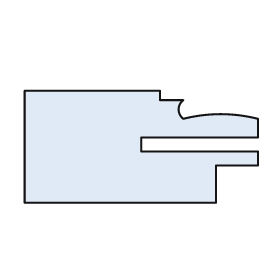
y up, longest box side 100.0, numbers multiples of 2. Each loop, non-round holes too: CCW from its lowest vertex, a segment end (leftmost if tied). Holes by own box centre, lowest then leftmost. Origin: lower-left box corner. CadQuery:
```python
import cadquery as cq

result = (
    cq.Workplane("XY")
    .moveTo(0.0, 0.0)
    .lineTo(82.0, 0.0)
    .lineTo(82.0, 16.0)
    .lineTo(100.0, 16.0)
    .lineTo(100.0, 22.0)
    .lineTo(50.0, 22.0)
    .lineTo(50.0, 28.0)
    .lineTo(100.0, 28.0)
    .lineTo(100.0, 36.0)
    .threePointArc((84.0, 38.0), (68.0, 36.0))
    .threePointArc((66.0, 40.0), (68.0, 44.0))
    .lineTo(58.0, 44.0)
    .lineTo(58.0, 48.0)
    .lineTo(0.0, 48.0)
    .close()
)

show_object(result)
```